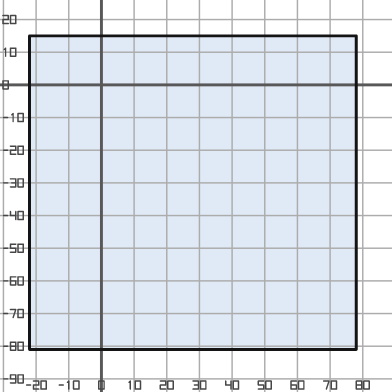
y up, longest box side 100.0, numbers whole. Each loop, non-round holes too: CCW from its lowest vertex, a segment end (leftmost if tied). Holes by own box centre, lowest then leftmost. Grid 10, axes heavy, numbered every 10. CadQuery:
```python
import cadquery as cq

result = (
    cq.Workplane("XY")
    .moveTo(-22.0, -81.0)
    .lineTo(78.0, -81.0)
    .lineTo(78.0, 15.0)
    .lineTo(-22.0, 15.0)
    .close()
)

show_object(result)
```